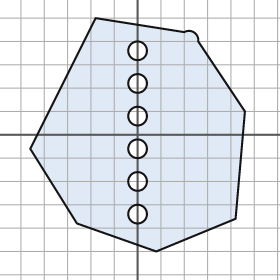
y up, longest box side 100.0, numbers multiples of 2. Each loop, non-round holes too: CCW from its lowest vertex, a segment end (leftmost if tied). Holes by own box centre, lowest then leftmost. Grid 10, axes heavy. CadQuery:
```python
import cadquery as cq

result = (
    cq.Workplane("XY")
    .moveTo(8.0, -50.0)
    .lineTo(42.0, -36.0)
    .lineTo(46.0, 10.0)
    .lineTo(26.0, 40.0)
    .threePointArc((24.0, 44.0), (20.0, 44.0))
    .lineTo(-18.0, 50.0)
    .lineTo(-46.0, -6.0)
    .lineTo(-26.0, -38.0)
    .close()
    .moveTo(0.0, -34.0)
    .circle(4.0)
    .moveTo(0.0, -20.0)
    .circle(4.0)
    .moveTo(0.0, -6.0)
    .circle(4.0)
    .moveTo(0.0, 8.0)
    .circle(4.0)
    .moveTo(0.0, 22.0)
    .circle(4.0)
    .moveTo(0.0, 36.0)
    .circle(4.0)
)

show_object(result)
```